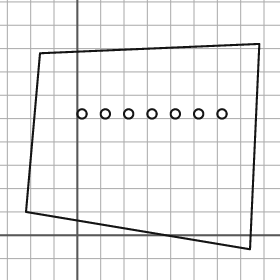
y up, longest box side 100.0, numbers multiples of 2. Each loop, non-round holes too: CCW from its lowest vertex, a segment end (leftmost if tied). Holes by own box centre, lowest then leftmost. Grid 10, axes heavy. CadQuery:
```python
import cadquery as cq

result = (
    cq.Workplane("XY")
    .moveTo(74.0, -6.0)
    .lineTo(78.0, 82.0)
    .lineTo(-16.0, 78.0)
    .lineTo(-22.0, 10.0)
    .close()
    .moveTo(2.0, 52.0)
    .circle(2.0)
    .moveTo(12.0, 52.0)
    .circle(2.0)
    .moveTo(22.0, 52.0)
    .circle(2.0)
    .moveTo(32.0, 52.0)
    .circle(2.0)
    .moveTo(42.0, 52.0)
    .circle(2.0)
    .moveTo(52.0, 52.0)
    .circle(2.0)
    .moveTo(62.0, 52.0)
    .circle(2.0)
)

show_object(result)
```